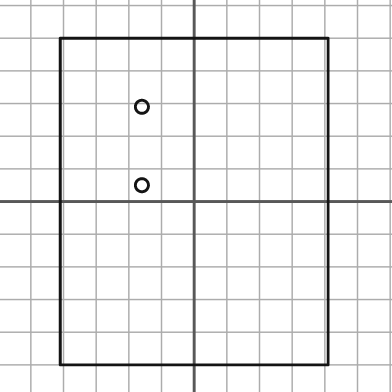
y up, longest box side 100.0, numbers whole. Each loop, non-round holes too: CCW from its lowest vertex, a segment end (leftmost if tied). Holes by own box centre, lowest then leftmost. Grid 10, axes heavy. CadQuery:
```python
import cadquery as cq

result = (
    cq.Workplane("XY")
    .moveTo(-41.0, -50.0)
    .lineTo(41.0, -50.0)
    .lineTo(41.0, 50.0)
    .lineTo(-41.0, 50.0)
    .close()
    .moveTo(-16.0, 5.0)
    .circle(2.0)
    .moveTo(-16.0, 29.0)
    .circle(2.0)
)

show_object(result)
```